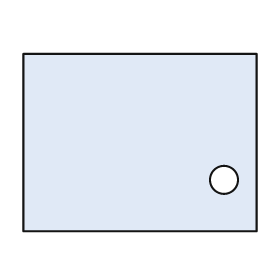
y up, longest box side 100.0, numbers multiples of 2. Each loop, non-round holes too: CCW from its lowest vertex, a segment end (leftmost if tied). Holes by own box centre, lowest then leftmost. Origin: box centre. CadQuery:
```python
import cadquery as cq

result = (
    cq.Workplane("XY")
    .moveTo(-50.0, -38.0)
    .lineTo(50.0, -38.0)
    .lineTo(50.0, 38.0)
    .lineTo(-50.0, 38.0)
    .close()
    .moveTo(36.0, -16.0)
    .circle(6.0)
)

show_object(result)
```